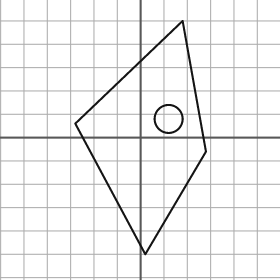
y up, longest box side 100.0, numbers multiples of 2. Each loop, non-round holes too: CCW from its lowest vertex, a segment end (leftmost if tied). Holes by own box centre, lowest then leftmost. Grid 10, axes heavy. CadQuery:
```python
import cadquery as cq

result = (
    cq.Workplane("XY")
    .moveTo(2.0, -50.0)
    .lineTo(28.0, -6.0)
    .lineTo(18.0, 50.0)
    .lineTo(-28.0, 6.0)
    .close()
    .moveTo(12.0, 8.0)
    .circle(6.0)
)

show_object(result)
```